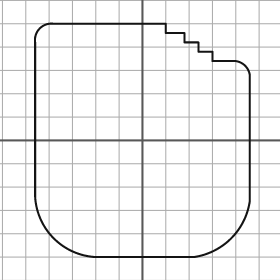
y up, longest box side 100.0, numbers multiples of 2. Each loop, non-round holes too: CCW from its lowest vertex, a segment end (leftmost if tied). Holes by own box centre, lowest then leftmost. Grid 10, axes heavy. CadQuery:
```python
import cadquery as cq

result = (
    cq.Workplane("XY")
    .moveTo(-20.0, -50.0)
    .lineTo(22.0, -50.0)
    .threePointArc((38.0, -42.0), (46.0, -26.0))
    .lineTo(46.0, 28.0)
    .threePointArc((44.0, 32.0), (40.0, 34.0))
    .lineTo(30.0, 34.0)
    .lineTo(30.0, 38.0)
    .lineTo(24.0, 38.0)
    .lineTo(24.0, 42.0)
    .lineTo(18.0, 42.0)
    .lineTo(18.0, 46.0)
    .lineTo(10.0, 46.0)
    .lineTo(10.0, 50.0)
    .lineTo(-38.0, 50.0)
    .threePointArc((-44.0, 48.0), (-46.0, 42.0))
    .lineTo(-46.0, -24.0)
    .threePointArc((-38.0, -42.0), (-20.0, -50.0))
    .close()
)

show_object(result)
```